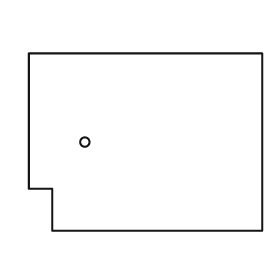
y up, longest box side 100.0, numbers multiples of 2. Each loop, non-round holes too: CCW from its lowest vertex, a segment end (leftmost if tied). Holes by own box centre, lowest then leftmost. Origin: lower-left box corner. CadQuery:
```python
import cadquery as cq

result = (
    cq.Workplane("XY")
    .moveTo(10.0, 0.0)
    .lineTo(100.0, 0.0)
    .lineTo(100.0, 76.0)
    .lineTo(0.0, 76.0)
    .lineTo(0.0, 18.0)
    .lineTo(10.0, 18.0)
    .close()
    .moveTo(24.0, 38.0)
    .circle(2.0)
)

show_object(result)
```